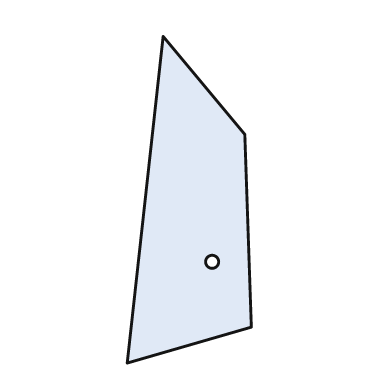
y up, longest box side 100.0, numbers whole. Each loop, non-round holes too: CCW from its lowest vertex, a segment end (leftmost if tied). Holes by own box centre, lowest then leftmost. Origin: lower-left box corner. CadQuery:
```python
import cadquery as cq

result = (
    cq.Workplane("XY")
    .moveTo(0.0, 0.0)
    .lineTo(38.0, 11.0)
    .lineTo(36.0, 70.0)
    .lineTo(11.0, 100.0)
    .close()
    .moveTo(26.0, 31.0)
    .circle(2.0)
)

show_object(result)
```